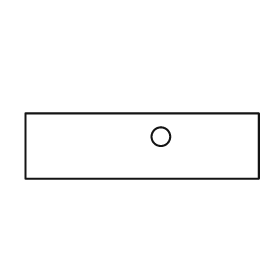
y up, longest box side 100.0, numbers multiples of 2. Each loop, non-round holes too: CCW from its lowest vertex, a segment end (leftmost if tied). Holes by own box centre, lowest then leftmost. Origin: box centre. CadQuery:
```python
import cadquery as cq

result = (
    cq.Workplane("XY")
    .moveTo(-50.0, -14.0)
    .lineTo(50.0, -14.0)
    .lineTo(50.0, 14.0)
    .lineTo(-50.0, 14.0)
    .close()
    .moveTo(8.0, 4.0)
    .circle(4.0)
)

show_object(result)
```